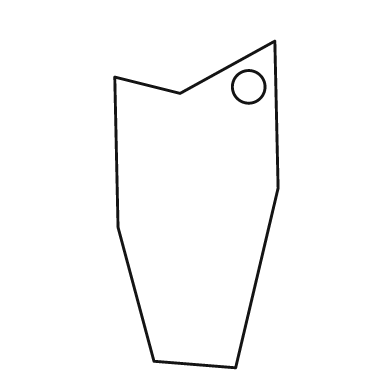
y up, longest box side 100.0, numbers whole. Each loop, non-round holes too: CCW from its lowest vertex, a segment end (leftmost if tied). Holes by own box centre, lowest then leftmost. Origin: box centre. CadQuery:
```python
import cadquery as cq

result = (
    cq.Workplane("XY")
    .moveTo(12.0, -50.0)
    .lineTo(25.0, 5.0)
    .lineTo(24.0, 50.0)
    .lineTo(-5.0, 34.0)
    .lineTo(-25.0, 39.0)
    .lineTo(-24.0, -7.0)
    .lineTo(-13.0, -48.0)
    .close()
    .moveTo(16.0, 36.0)
    .circle(5.0)
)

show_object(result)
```